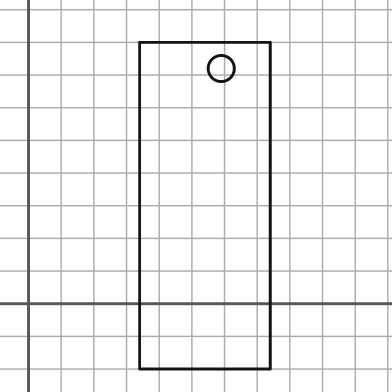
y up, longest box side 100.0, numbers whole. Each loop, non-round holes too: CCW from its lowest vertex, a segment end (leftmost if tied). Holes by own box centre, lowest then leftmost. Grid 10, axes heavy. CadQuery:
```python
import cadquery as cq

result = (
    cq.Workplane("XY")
    .moveTo(34.0, -20.0)
    .lineTo(74.0, -20.0)
    .lineTo(74.0, 80.0)
    .lineTo(34.0, 80.0)
    .close()
    .moveTo(59.0, 72.0)
    .circle(4.0)
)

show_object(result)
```